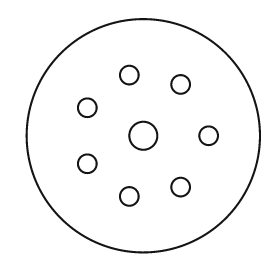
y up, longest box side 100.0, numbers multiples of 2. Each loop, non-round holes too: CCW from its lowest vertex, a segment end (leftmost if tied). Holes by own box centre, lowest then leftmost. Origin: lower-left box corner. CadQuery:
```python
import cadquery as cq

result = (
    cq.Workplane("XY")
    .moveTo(50.0, 50.0)
    .circle(50.0)
    .moveTo(44.0, 24.0)
    .circle(4.0)
    .moveTo(66.0, 28.0)
    .circle(4.0)
    .moveTo(26.0, 38.0)
    .circle(4.0)
    .moveTo(50.0, 50.0)
    .circle(6.0)
    .moveTo(78.0, 50.0)
    .circle(4.0)
    .moveTo(26.0, 62.0)
    .circle(4.0)
    .moveTo(66.0, 72.0)
    .circle(4.0)
    .moveTo(44.0, 76.0)
    .circle(4.0)
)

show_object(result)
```